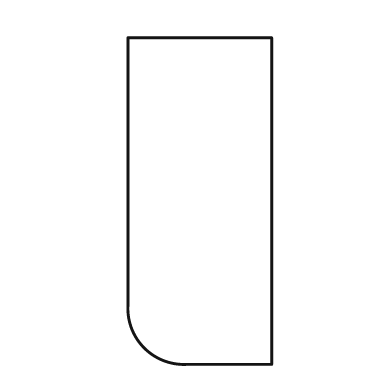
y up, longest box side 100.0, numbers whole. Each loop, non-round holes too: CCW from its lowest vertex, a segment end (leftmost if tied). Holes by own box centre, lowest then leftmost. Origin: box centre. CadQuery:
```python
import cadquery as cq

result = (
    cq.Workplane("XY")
    .moveTo(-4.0, -50.0)
    .lineTo(22.0, -50.0)
    .lineTo(22.0, 50.0)
    .lineTo(-22.0, 50.0)
    .lineTo(-22.0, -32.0)
    .threePointArc((-17.0, -45.0), (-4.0, -50.0))
    .close()
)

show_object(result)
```